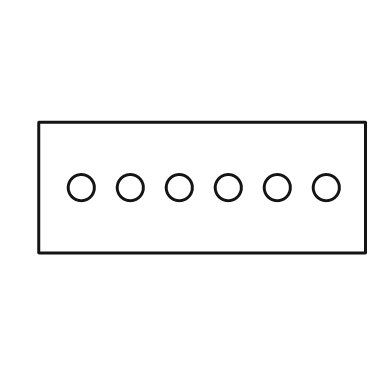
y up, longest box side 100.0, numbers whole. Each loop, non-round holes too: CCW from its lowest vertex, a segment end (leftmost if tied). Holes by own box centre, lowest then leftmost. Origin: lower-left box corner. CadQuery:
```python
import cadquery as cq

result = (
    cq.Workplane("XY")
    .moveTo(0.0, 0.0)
    .lineTo(100.0, 0.0)
    .lineTo(100.0, 40.0)
    .lineTo(0.0, 40.0)
    .close()
    .moveTo(13.0, 20.0)
    .circle(4.0)
    .moveTo(28.0, 20.0)
    .circle(4.0)
    .moveTo(43.0, 20.0)
    .circle(4.0)
    .moveTo(58.0, 20.0)
    .circle(4.0)
    .moveTo(73.0, 20.0)
    .circle(4.0)
    .moveTo(88.0, 20.0)
    .circle(4.0)
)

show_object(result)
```